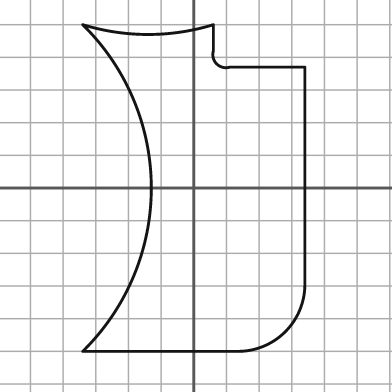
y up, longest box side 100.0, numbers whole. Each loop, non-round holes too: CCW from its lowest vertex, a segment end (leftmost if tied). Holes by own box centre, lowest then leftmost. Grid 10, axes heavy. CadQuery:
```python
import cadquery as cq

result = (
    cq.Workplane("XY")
    .moveTo(-34.0, -50.0)
    .lineTo(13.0, -50.0)
    .threePointArc((28.0, -44.0), (34.0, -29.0))
    .lineTo(34.0, 37.0)
    .lineTo(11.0, 37.0)
    .threePointArc((7.0, 38.0), (6.0, 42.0))
    .lineTo(6.0, 50.0)
    .threePointArc((-14.0, 47.0), (-34.0, 50.0))
    .threePointArc((-13.0, 0.0), (-34.0, -50.0))
    .close()
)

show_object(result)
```